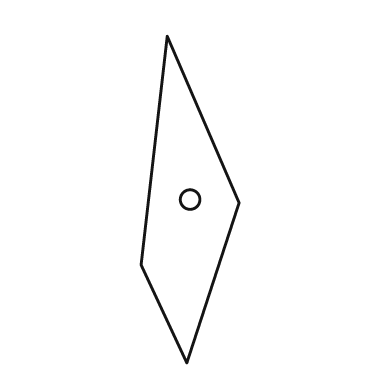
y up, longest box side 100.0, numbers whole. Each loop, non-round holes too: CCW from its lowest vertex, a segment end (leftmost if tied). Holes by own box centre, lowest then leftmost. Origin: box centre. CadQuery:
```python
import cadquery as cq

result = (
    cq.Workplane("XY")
    .moveTo(-1.0, -50.0)
    .lineTo(15.0, -1.0)
    .lineTo(-7.0, 50.0)
    .lineTo(-15.0, -20.0)
    .close()
    .moveTo(0.0, 0.0)
    .circle(3.0)
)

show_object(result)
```